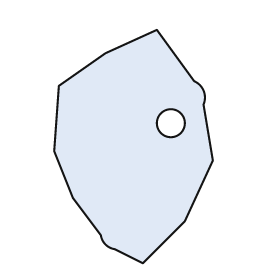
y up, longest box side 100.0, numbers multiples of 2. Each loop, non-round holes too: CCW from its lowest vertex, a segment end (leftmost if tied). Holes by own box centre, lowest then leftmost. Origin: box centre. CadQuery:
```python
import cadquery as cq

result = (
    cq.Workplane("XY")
    .moveTo(4.0, -50.0)
    .lineTo(22.0, -32.0)
    .lineTo(34.0, -6.0)
    .lineTo(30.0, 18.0)
    .threePointArc((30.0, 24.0), (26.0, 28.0))
    .lineTo(10.0, 50.0)
    .lineTo(-12.0, 40.0)
    .lineTo(-32.0, 26.0)
    .lineTo(-34.0, -2.0)
    .lineTo(-26.0, -22.0)
    .lineTo(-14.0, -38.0)
    .threePointArc((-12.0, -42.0), (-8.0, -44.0))
    .close()
    .moveTo(16.0, 10.0)
    .circle(6.0)
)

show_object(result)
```